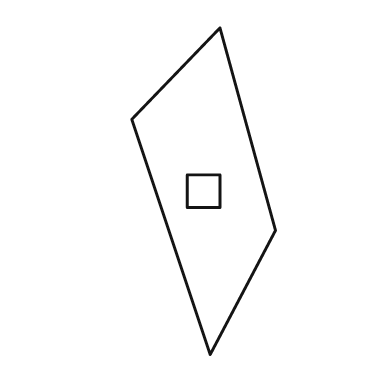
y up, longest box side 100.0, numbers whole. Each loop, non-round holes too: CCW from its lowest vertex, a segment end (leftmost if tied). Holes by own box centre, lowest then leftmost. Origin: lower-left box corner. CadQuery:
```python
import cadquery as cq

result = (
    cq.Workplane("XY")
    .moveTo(24.0, 0.0)
    .lineTo(44.0, 38.0)
    .lineTo(27.0, 100.0)
    .lineTo(0.0, 72.0)
    .close()
    .moveTo(17.0, 45.0)
    .lineTo(27.0, 45.0)
    .lineTo(27.0, 55.0)
    .lineTo(17.0, 55.0)
    .close()
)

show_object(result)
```